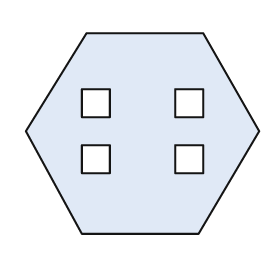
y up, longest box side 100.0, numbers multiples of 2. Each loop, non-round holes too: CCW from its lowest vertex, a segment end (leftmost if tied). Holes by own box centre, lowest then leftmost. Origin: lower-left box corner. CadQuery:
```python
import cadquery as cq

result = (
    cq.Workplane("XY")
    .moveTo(24.0, 0.0)
    .lineTo(74.0, 0.0)
    .lineTo(100.0, 44.0)
    .lineTo(76.0, 86.0)
    .lineTo(26.0, 86.0)
    .lineTo(0.0, 44.0)
    .close()
    .moveTo(24.0, 26.0)
    .lineTo(36.0, 26.0)
    .lineTo(36.0, 38.0)
    .lineTo(24.0, 38.0)
    .close()
    .moveTo(64.0, 26.0)
    .lineTo(76.0, 26.0)
    .lineTo(76.0, 38.0)
    .lineTo(64.0, 38.0)
    .close()
    .moveTo(24.0, 50.0)
    .lineTo(36.0, 50.0)
    .lineTo(36.0, 62.0)
    .lineTo(24.0, 62.0)
    .close()
    .moveTo(64.0, 50.0)
    .lineTo(76.0, 50.0)
    .lineTo(76.0, 62.0)
    .lineTo(64.0, 62.0)
    .close()
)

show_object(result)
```